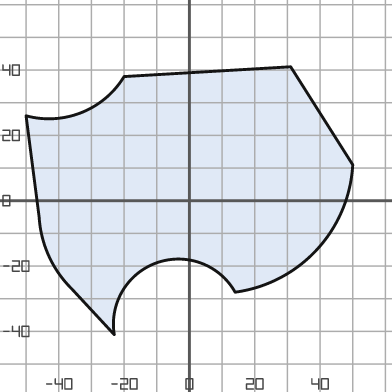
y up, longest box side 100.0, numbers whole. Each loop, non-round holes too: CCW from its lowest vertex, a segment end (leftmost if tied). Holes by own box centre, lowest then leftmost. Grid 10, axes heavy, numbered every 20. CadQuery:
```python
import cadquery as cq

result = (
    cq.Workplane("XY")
    .moveTo(-23.0, -41.0)
    .threePointArc((-10.0, -19.0), (14.0, -28.0))
    .threePointArc((39.0, -15.0), (50.0, 11.0))
    .lineTo(31.0, 41.0)
    .lineTo(-20.0, 38.0)
    .threePointArc((-33.0, 27.0), (-50.0, 26.0))
    .lineTo(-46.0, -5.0)
    .threePointArc((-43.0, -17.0), (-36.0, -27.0))
    .close()
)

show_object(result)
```